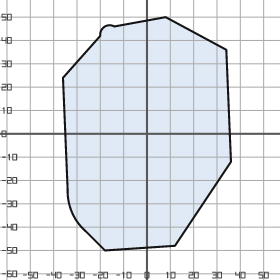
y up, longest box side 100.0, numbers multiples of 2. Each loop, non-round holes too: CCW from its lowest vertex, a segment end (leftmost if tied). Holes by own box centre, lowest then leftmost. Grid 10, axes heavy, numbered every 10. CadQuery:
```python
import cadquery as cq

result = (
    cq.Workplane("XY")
    .moveTo(-18.0, -50.0)
    .lineTo(12.0, -48.0)
    .lineTo(36.0, -12.0)
    .lineTo(34.0, 36.0)
    .lineTo(8.0, 50.0)
    .lineTo(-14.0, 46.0)
    .threePointArc((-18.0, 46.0), (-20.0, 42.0))
    .lineTo(-36.0, 24.0)
    .lineTo(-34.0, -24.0)
    .threePointArc((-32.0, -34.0), (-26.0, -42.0))
    .close()
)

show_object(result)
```